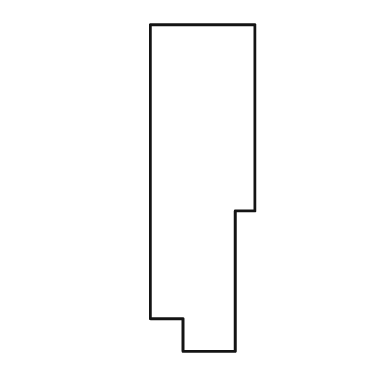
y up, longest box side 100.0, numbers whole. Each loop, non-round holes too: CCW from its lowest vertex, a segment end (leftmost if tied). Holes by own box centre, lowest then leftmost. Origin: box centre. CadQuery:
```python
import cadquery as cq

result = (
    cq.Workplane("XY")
    .moveTo(-6.0, -50.0)
    .lineTo(10.0, -50.0)
    .lineTo(10.0, -7.0)
    .lineTo(16.0, -7.0)
    .lineTo(16.0, 50.0)
    .lineTo(-16.0, 50.0)
    .lineTo(-16.0, -40.0)
    .lineTo(-6.0, -40.0)
    .close()
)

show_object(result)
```